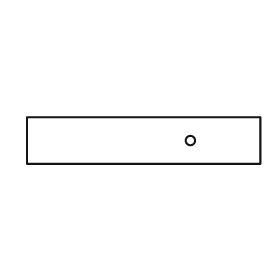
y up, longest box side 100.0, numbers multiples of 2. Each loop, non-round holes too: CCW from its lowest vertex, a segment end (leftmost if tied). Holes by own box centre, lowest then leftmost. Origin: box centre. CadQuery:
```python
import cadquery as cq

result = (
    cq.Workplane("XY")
    .moveTo(-50.0, -10.0)
    .lineTo(50.0, -10.0)
    .lineTo(50.0, 10.0)
    .lineTo(-50.0, 10.0)
    .close()
    .moveTo(20.0, 0.0)
    .circle(2.0)
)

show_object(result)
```